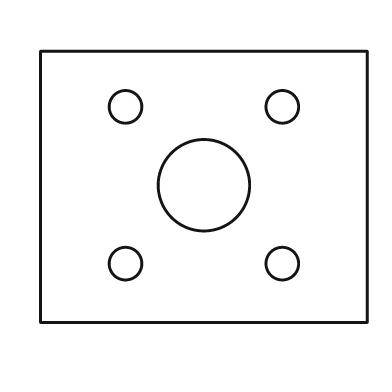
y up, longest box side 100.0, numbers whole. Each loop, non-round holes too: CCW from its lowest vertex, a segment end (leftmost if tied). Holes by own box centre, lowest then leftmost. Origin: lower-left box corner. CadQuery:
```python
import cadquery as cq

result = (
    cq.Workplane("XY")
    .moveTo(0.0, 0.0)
    .lineTo(100.0, 0.0)
    .lineTo(100.0, 83.0)
    .lineTo(0.0, 83.0)
    .close()
    .moveTo(26.0, 18.0)
    .circle(5.0)
    .moveTo(74.0, 18.0)
    .circle(5.0)
    .moveTo(50.0, 42.0)
    .circle(14.0)
    .moveTo(26.0, 66.0)
    .circle(5.0)
    .moveTo(74.0, 66.0)
    .circle(5.0)
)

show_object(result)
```